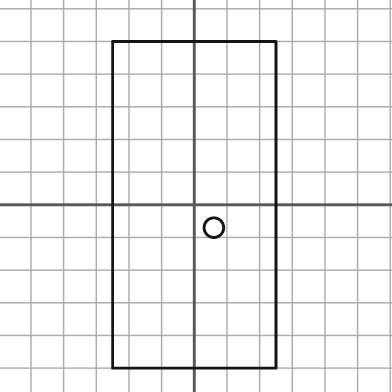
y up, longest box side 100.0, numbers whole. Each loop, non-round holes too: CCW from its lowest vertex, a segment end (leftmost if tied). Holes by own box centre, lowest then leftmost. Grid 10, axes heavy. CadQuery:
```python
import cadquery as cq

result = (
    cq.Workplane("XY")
    .moveTo(-25.0, -50.0)
    .lineTo(25.0, -50.0)
    .lineTo(25.0, 50.0)
    .lineTo(-25.0, 50.0)
    .close()
    .moveTo(6.0, -7.0)
    .circle(3.0)
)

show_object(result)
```